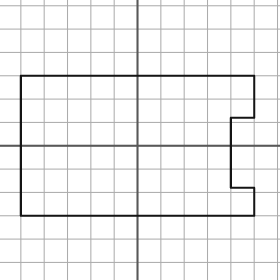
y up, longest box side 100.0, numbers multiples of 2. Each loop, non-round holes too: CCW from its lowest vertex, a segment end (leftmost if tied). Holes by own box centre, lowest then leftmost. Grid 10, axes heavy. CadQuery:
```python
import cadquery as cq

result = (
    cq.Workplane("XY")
    .moveTo(-50.0, -30.0)
    .lineTo(50.0, -30.0)
    .lineTo(50.0, -18.0)
    .lineTo(40.0, -18.0)
    .lineTo(40.0, 12.0)
    .lineTo(50.0, 12.0)
    .lineTo(50.0, 30.0)
    .lineTo(-50.0, 30.0)
    .close()
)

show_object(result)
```